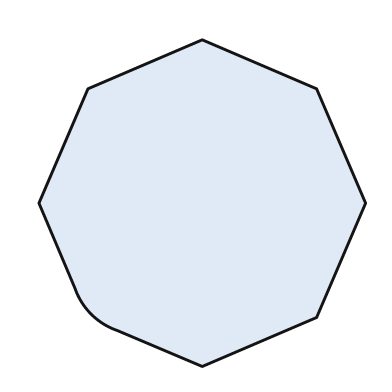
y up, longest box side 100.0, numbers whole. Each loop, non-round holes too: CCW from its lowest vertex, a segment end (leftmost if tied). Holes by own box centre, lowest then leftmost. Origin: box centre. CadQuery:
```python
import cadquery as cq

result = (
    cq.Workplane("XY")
    .moveTo(0.0, -50.0)
    .lineTo(35.0, -35.0)
    .lineTo(50.0, 0.0)
    .lineTo(35.0, 35.0)
    .lineTo(0.0, 50.0)
    .lineTo(-35.0, 35.0)
    .lineTo(-50.0, 0.0)
    .lineTo(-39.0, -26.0)
    .threePointArc((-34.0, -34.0), (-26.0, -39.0))
    .close()
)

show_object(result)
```